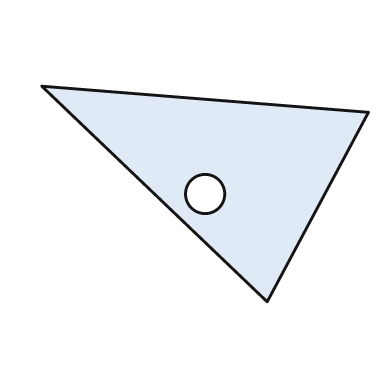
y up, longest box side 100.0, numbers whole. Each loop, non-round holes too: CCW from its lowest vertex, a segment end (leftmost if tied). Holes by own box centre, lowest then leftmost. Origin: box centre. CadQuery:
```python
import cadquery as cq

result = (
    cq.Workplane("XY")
    .moveTo(19.0, -33.0)
    .lineTo(50.0, 25.0)
    .lineTo(-50.0, 33.0)
    .close()
    .moveTo(0.0, 0.0)
    .circle(6.0)
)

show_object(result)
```